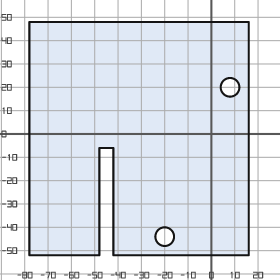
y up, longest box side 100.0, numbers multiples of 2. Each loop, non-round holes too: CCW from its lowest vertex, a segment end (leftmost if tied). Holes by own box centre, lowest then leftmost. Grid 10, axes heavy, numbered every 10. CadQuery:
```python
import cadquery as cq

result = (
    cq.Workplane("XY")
    .moveTo(-78.0, -52.0)
    .lineTo(-48.0, -52.0)
    .lineTo(-48.0, -6.0)
    .lineTo(-42.0, -6.0)
    .lineTo(-42.0, -52.0)
    .lineTo(16.0, -52.0)
    .lineTo(16.0, 48.0)
    .lineTo(-78.0, 48.0)
    .close()
    .moveTo(-20.0, -44.0)
    .circle(4.0)
    .moveTo(8.0, 20.0)
    .circle(4.0)
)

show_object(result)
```